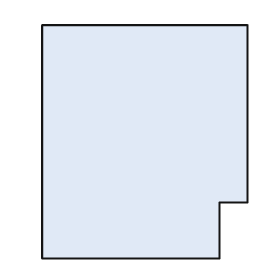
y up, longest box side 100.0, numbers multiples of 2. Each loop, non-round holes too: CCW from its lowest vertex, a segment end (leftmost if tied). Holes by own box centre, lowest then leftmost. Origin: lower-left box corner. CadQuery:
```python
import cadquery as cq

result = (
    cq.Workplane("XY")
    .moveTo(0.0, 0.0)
    .lineTo(76.0, 0.0)
    .lineTo(76.0, 24.0)
    .lineTo(88.0, 24.0)
    .lineTo(88.0, 100.0)
    .lineTo(0.0, 100.0)
    .close()
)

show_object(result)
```